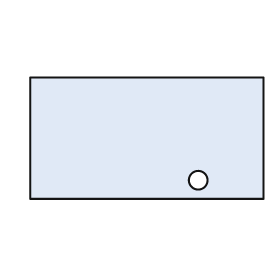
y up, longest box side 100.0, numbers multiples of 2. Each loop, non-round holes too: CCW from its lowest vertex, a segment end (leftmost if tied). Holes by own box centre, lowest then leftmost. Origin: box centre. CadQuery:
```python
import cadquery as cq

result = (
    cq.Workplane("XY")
    .moveTo(-50.0, -26.0)
    .lineTo(50.0, -26.0)
    .lineTo(50.0, 26.0)
    .lineTo(-50.0, 26.0)
    .close()
    .moveTo(22.0, -18.0)
    .circle(4.0)
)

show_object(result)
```